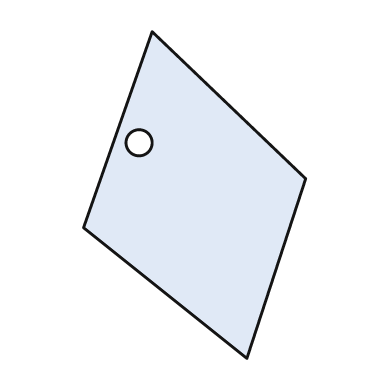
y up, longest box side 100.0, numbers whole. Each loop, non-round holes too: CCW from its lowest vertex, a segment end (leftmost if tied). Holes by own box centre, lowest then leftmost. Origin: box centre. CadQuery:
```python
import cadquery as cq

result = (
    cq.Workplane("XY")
    .moveTo(16.0, -50.0)
    .lineTo(34.0, 5.0)
    .lineTo(-13.0, 50.0)
    .lineTo(-34.0, -10.0)
    .close()
    .moveTo(-17.0, 16.0)
    .circle(4.0)
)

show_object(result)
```